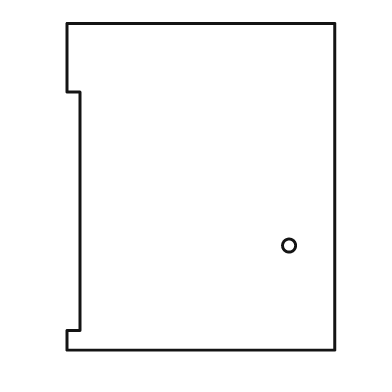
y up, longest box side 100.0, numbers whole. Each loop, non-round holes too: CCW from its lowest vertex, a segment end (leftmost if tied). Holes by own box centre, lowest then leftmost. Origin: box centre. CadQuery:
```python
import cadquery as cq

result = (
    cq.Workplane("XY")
    .moveTo(-41.0, -50.0)
    .lineTo(41.0, -50.0)
    .lineTo(41.0, 50.0)
    .lineTo(-41.0, 50.0)
    .lineTo(-41.0, 29.0)
    .lineTo(-37.0, 29.0)
    .lineTo(-37.0, -44.0)
    .lineTo(-41.0, -44.0)
    .close()
    .moveTo(27.0, -18.0)
    .circle(2.0)
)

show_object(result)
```